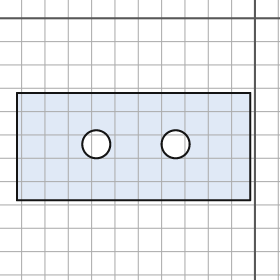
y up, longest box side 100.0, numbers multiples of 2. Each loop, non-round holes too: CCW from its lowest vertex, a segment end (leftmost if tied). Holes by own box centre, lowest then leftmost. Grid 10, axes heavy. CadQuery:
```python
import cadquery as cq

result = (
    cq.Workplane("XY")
    .moveTo(-102.0, -78.0)
    .lineTo(-2.0, -78.0)
    .lineTo(-2.0, -32.0)
    .lineTo(-102.0, -32.0)
    .close()
    .moveTo(-68.0, -54.0)
    .circle(6.0)
    .moveTo(-34.0, -54.0)
    .circle(6.0)
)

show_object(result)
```